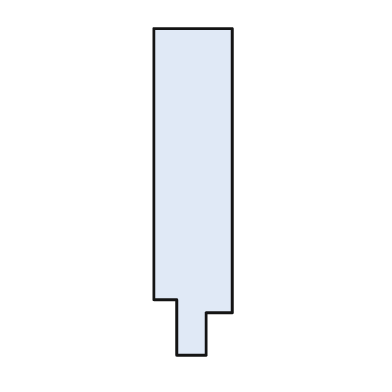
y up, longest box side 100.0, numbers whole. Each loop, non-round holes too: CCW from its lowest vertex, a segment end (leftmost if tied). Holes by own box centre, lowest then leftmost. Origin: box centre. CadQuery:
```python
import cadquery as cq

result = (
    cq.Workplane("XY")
    .moveTo(-5.0, -50.0)
    .lineTo(4.0, -50.0)
    .lineTo(4.0, -37.0)
    .lineTo(12.0, -37.0)
    .lineTo(12.0, 50.0)
    .lineTo(-12.0, 50.0)
    .lineTo(-12.0, -33.0)
    .lineTo(-5.0, -33.0)
    .close()
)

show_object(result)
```